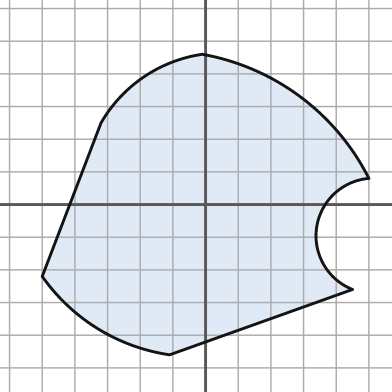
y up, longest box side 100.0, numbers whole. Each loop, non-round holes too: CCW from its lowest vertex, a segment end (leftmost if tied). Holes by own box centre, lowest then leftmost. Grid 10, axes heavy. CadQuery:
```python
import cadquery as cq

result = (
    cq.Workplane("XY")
    .moveTo(-11.0, -46.0)
    .lineTo(45.0, -26.0)
    .threePointArc((34.0, -7.0), (50.0, 8.0))
    .threePointArc((29.0, 33.0), (-1.0, 46.0))
    .threePointArc((-19.0, 39.0), (-32.0, 25.0))
    .lineTo(-50.0, -22.0)
    .threePointArc((-33.0, -38.0), (-11.0, -46.0))
    .close()
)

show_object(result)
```